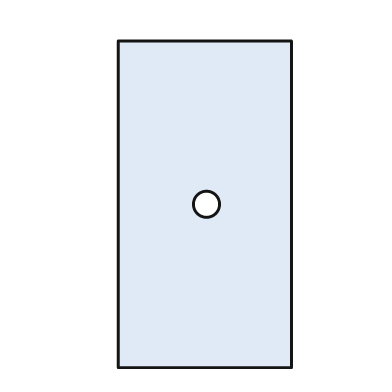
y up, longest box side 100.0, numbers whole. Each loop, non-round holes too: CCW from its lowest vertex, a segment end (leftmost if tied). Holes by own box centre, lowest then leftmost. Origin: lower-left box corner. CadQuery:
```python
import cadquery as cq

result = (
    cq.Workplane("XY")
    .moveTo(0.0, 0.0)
    .lineTo(53.0, 0.0)
    .lineTo(53.0, 100.0)
    .lineTo(0.0, 100.0)
    .close()
    .moveTo(27.0, 50.0)
    .circle(4.0)
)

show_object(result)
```